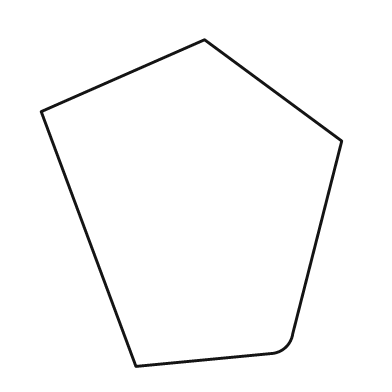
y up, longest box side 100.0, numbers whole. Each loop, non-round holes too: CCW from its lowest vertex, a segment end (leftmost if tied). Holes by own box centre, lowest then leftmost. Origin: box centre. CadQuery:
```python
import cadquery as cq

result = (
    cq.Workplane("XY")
    .moveTo(-17.0, -50.0)
    .lineTo(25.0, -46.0)
    .threePointArc((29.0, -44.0), (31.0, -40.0))
    .lineTo(46.0, 19.0)
    .lineTo(4.0, 50.0)
    .lineTo(-46.0, 28.0)
    .close()
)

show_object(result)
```